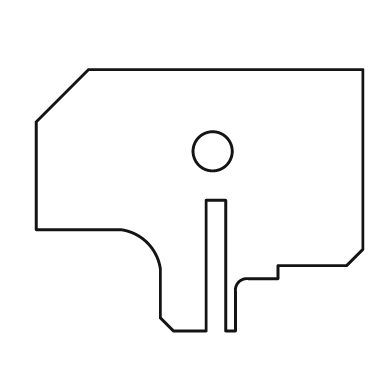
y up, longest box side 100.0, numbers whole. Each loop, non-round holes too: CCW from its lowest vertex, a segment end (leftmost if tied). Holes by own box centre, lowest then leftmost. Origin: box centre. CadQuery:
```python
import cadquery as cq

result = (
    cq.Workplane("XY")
    .moveTo(-8.0, -40.0)
    .lineTo(2.0, -40.0)
    .lineTo(2.0, 0.0)
    .lineTo(8.0, 0.0)
    .lineTo(8.0, -40.0)
    .lineTo(11.0, -40.0)
    .lineTo(11.0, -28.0)
    .threePointArc((12.0, -25.0), (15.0, -24.0))
    .lineTo(24.0, -24.0)
    .lineTo(24.0, -20.0)
    .lineTo(45.0, -20.0)
    .lineTo(50.0, -15.0)
    .lineTo(50.0, 40.0)
    .lineTo(-34.0, 40.0)
    .lineTo(-50.0, 24.0)
    .lineTo(-50.0, -9.0)
    .lineTo(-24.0, -9.0)
    .threePointArc((-16.0, -13.0), (-12.0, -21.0))
    .lineTo(-12.0, -36.0)
    .close()
    .moveTo(4.0, 15.0)
    .circle(6.0)
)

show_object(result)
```